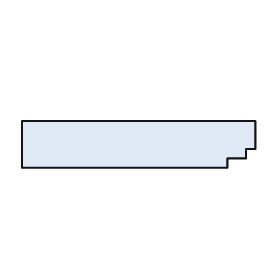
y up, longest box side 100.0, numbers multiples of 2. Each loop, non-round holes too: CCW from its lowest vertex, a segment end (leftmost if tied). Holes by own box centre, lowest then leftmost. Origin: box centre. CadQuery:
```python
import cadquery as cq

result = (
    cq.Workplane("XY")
    .moveTo(-50.0, -10.0)
    .lineTo(38.0, -10.0)
    .lineTo(38.0, -6.0)
    .lineTo(46.0, -6.0)
    .lineTo(46.0, -2.0)
    .lineTo(50.0, -2.0)
    .lineTo(50.0, 10.0)
    .lineTo(-50.0, 10.0)
    .close()
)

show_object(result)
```